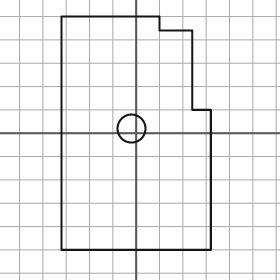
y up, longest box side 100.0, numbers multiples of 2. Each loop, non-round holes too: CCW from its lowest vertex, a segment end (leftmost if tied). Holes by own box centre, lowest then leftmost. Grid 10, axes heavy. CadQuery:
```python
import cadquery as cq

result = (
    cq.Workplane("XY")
    .moveTo(-32.0, -50.0)
    .lineTo(32.0, -50.0)
    .lineTo(32.0, 10.0)
    .lineTo(24.0, 10.0)
    .lineTo(24.0, 44.0)
    .lineTo(10.0, 44.0)
    .lineTo(10.0, 50.0)
    .lineTo(-32.0, 50.0)
    .close()
    .moveTo(-2.0, 2.0)
    .circle(6.0)
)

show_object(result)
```